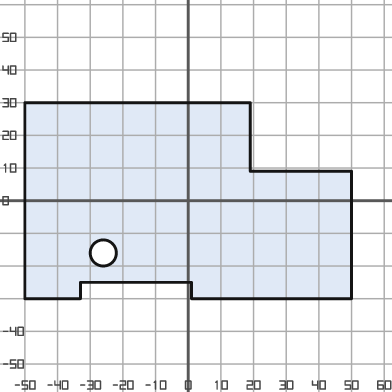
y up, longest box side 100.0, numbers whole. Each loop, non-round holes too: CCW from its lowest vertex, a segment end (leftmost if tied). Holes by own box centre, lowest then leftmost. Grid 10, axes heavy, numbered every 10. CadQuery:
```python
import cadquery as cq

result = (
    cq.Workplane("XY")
    .moveTo(-50.0, -30.0)
    .lineTo(-33.0, -30.0)
    .lineTo(-33.0, -25.0)
    .lineTo(1.0, -25.0)
    .lineTo(1.0, -30.0)
    .lineTo(50.0, -30.0)
    .lineTo(50.0, 9.0)
    .lineTo(19.0, 9.0)
    .lineTo(19.0, 30.0)
    .lineTo(-50.0, 30.0)
    .close()
    .moveTo(-26.0, -16.0)
    .circle(4.0)
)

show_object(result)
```